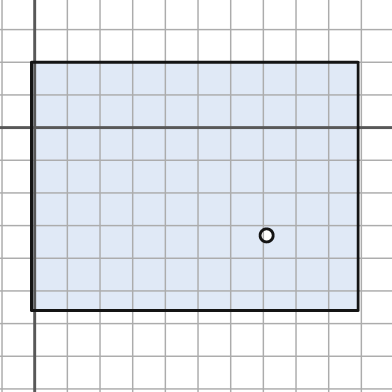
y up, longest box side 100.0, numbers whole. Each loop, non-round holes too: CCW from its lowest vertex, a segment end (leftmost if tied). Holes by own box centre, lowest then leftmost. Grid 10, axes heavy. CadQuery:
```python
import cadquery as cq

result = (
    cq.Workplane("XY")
    .moveTo(-1.0, -56.0)
    .lineTo(99.0, -56.0)
    .lineTo(99.0, 20.0)
    .lineTo(-1.0, 20.0)
    .close()
    .moveTo(71.0, -33.0)
    .circle(2.0)
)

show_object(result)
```